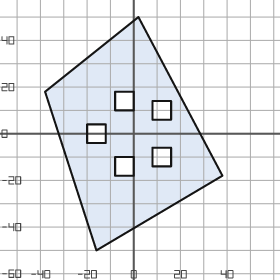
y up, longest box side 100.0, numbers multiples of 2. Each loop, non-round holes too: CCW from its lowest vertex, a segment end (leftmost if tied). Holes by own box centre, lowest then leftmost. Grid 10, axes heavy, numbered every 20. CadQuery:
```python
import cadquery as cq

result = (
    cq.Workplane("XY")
    .moveTo(-16.0, -50.0)
    .lineTo(38.0, -18.0)
    .lineTo(2.0, 50.0)
    .lineTo(-38.0, 18.0)
    .close()
    .moveTo(-8.0, -18.0)
    .lineTo(0.0, -18.0)
    .lineTo(0.0, -10.0)
    .lineTo(-8.0, -10.0)
    .close()
    .moveTo(8.0, -14.0)
    .lineTo(16.0, -14.0)
    .lineTo(16.0, -6.0)
    .lineTo(8.0, -6.0)
    .close()
    .moveTo(-20.0, -4.0)
    .lineTo(-12.0, -4.0)
    .lineTo(-12.0, 4.0)
    .lineTo(-20.0, 4.0)
    .close()
    .moveTo(8.0, 6.0)
    .lineTo(16.0, 6.0)
    .lineTo(16.0, 14.0)
    .lineTo(8.0, 14.0)
    .close()
    .moveTo(-8.0, 10.0)
    .lineTo(0.0, 10.0)
    .lineTo(0.0, 18.0)
    .lineTo(-8.0, 18.0)
    .close()
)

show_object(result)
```